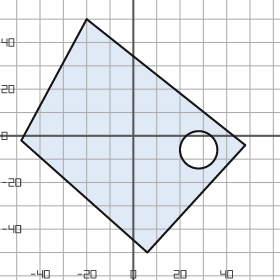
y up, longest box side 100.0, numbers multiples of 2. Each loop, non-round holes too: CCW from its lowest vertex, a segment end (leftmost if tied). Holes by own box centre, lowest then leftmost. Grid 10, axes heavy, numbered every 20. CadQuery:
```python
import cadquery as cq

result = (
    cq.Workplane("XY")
    .moveTo(6.0, -50.0)
    .lineTo(48.0, -4.0)
    .lineTo(-20.0, 50.0)
    .lineTo(-48.0, -2.0)
    .close()
    .moveTo(28.0, -6.0)
    .circle(8.0)
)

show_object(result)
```